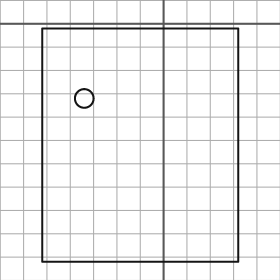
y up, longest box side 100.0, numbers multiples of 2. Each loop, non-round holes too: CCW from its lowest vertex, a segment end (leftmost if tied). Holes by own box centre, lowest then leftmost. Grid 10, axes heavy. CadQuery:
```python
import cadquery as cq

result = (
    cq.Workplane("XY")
    .moveTo(-52.0, -102.0)
    .lineTo(32.0, -102.0)
    .lineTo(32.0, -2.0)
    .lineTo(-52.0, -2.0)
    .close()
    .moveTo(-34.0, -32.0)
    .circle(4.0)
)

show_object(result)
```